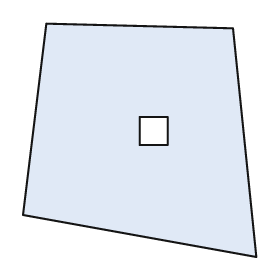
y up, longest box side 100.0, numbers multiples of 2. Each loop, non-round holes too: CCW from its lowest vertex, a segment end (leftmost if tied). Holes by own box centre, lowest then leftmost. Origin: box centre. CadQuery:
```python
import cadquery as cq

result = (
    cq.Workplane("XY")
    .moveTo(50.0, -50.0)
    .lineTo(40.0, 48.0)
    .lineTo(-40.0, 50.0)
    .lineTo(-50.0, -32.0)
    .close()
    .moveTo(0.0, -2.0)
    .lineTo(12.0, -2.0)
    .lineTo(12.0, 10.0)
    .lineTo(0.0, 10.0)
    .close()
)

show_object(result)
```